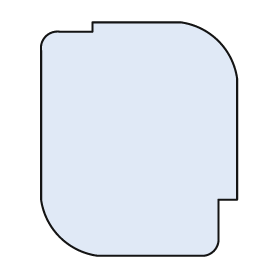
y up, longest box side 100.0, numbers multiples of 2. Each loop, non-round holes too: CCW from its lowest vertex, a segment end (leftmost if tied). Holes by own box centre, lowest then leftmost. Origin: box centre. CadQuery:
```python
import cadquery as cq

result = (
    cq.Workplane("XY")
    .moveTo(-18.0, -50.0)
    .lineTo(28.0, -50.0)
    .threePointArc((32.0, -48.0), (34.0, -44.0))
    .lineTo(34.0, -26.0)
    .lineTo(42.0, -26.0)
    .lineTo(42.0, 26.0)
    .threePointArc((34.0, 42.0), (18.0, 50.0))
    .lineTo(-20.0, 50.0)
    .lineTo(-20.0, 46.0)
    .lineTo(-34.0, 46.0)
    .threePointArc((-40.0, 44.0), (-42.0, 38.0))
    .lineTo(-42.0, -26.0)
    .threePointArc((-34.0, -42.0), (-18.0, -50.0))
    .close()
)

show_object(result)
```